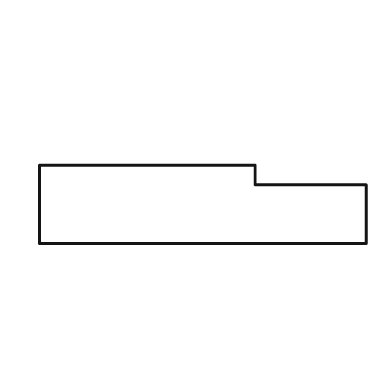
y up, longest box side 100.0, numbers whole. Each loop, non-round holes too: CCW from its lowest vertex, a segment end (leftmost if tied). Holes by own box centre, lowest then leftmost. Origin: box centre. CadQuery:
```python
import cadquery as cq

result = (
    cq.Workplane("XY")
    .moveTo(-50.0, -12.0)
    .lineTo(50.0, -12.0)
    .lineTo(50.0, 6.0)
    .lineTo(16.0, 6.0)
    .lineTo(16.0, 12.0)
    .lineTo(-50.0, 12.0)
    .close()
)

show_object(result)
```